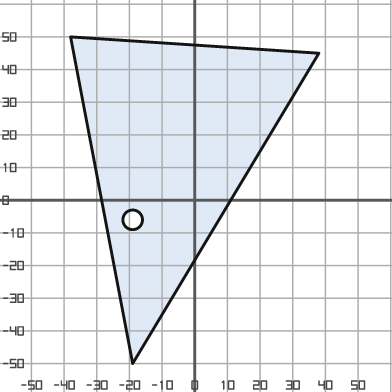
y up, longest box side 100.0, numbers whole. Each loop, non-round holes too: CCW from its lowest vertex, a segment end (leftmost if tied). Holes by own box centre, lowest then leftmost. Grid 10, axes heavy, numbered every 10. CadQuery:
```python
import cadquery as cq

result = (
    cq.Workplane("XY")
    .moveTo(-19.0, -50.0)
    .lineTo(38.0, 45.0)
    .lineTo(-38.0, 50.0)
    .close()
    .moveTo(-19.0, -6.0)
    .circle(3.0)
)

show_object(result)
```